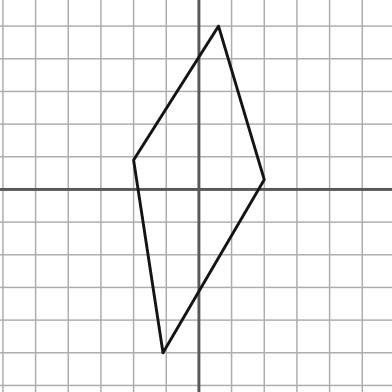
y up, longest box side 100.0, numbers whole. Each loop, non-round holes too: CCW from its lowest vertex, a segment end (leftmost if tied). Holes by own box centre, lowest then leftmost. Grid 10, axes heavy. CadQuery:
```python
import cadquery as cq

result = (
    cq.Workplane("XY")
    .moveTo(-11.0, -50.0)
    .lineTo(20.0, 3.0)
    .lineTo(6.0, 50.0)
    .lineTo(-20.0, 9.0)
    .close()
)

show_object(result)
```